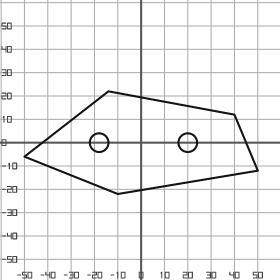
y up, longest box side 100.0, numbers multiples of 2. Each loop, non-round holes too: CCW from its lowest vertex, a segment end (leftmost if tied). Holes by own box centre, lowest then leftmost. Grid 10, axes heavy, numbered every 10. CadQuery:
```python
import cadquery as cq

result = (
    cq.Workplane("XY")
    .moveTo(-10.0, -22.0)
    .lineTo(50.0, -12.0)
    .lineTo(40.0, 12.0)
    .lineTo(-14.0, 22.0)
    .lineTo(-50.0, -6.0)
    .close()
    .moveTo(-18.0, 0.0)
    .circle(4.0)
    .moveTo(20.0, 0.0)
    .circle(4.0)
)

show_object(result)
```